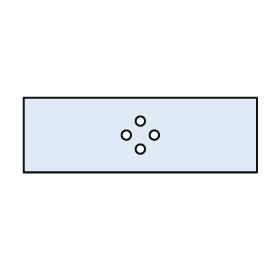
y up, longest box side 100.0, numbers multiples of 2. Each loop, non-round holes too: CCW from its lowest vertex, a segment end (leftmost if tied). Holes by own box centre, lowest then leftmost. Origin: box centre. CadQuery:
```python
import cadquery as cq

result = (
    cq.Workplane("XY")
    .moveTo(-50.0, -16.0)
    .lineTo(50.0, -16.0)
    .lineTo(50.0, 16.0)
    .lineTo(-50.0, 16.0)
    .close()
    .moveTo(0.0, -6.0)
    .circle(2.0)
    .moveTo(-6.0, 0.0)
    .circle(2.0)
    .moveTo(6.0, 0.0)
    .circle(2.0)
    .moveTo(0.0, 6.0)
    .circle(2.0)
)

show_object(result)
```